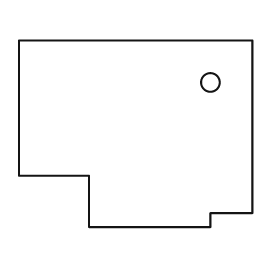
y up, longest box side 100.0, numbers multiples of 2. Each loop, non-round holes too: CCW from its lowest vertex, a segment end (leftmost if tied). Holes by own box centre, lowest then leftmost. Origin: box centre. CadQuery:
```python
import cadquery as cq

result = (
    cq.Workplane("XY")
    .moveTo(-20.0, -40.0)
    .lineTo(32.0, -40.0)
    .lineTo(32.0, -34.0)
    .lineTo(50.0, -34.0)
    .lineTo(50.0, 40.0)
    .lineTo(-50.0, 40.0)
    .lineTo(-50.0, -18.0)
    .lineTo(-20.0, -18.0)
    .close()
    .moveTo(32.0, 22.0)
    .circle(4.0)
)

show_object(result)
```